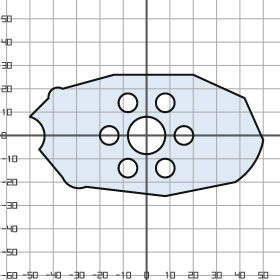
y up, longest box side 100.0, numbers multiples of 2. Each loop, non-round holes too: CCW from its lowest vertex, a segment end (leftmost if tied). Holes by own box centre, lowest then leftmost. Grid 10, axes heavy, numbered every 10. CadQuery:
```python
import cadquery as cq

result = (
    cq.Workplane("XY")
    .moveTo(8.0, -26.0)
    .lineTo(38.0, -20.0)
    .threePointArc((46.0, -12.0), (50.0, -2.0))
    .lineTo(42.0, 16.0)
    .lineTo(20.0, 26.0)
    .lineTo(-14.0, 26.0)
    .lineTo(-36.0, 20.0)
    .threePointArc((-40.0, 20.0), (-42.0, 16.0))
    .lineTo(-50.0, 8.0)
    .threePointArc((-44.0, 2.0), (-46.0, -6.0))
    .lineTo(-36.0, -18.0)
    .threePointArc((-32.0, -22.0), (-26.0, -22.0))
    .close()
    .moveTo(-8.0, -14.0)
    .circle(4.0)
    .moveTo(8.0, -14.0)
    .circle(4.0)
    .moveTo(-16.0, 0.0)
    .circle(4.0)
    .moveTo(0.0, 0.0)
    .circle(8.0)
    .moveTo(16.0, 0.0)
    .circle(4.0)
    .moveTo(-8.0, 14.0)
    .circle(4.0)
    .moveTo(8.0, 14.0)
    .circle(4.0)
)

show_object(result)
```